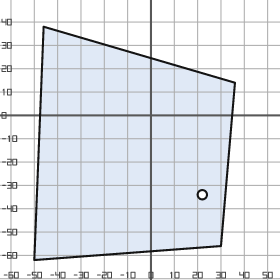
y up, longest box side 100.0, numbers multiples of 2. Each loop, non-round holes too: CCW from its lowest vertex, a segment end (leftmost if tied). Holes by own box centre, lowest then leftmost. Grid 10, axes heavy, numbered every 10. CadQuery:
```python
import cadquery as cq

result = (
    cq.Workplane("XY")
    .moveTo(-50.0, -62.0)
    .lineTo(30.0, -56.0)
    .lineTo(36.0, 14.0)
    .lineTo(-46.0, 38.0)
    .close()
    .moveTo(22.0, -34.0)
    .circle(2.0)
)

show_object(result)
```